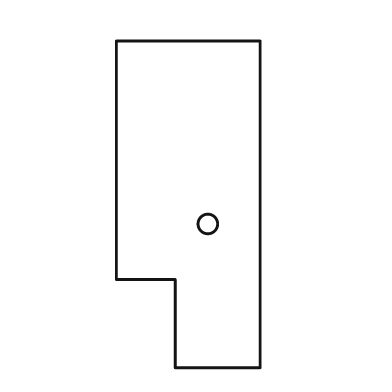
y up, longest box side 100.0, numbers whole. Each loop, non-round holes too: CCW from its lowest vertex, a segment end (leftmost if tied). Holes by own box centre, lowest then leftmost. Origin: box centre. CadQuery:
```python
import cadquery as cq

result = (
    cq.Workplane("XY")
    .moveTo(-4.0, -50.0)
    .lineTo(22.0, -50.0)
    .lineTo(22.0, 50.0)
    .lineTo(-22.0, 50.0)
    .lineTo(-22.0, -23.0)
    .lineTo(-4.0, -23.0)
    .close()
    .moveTo(6.0, -6.0)
    .circle(3.0)
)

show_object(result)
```